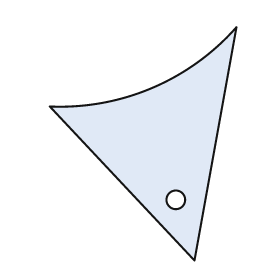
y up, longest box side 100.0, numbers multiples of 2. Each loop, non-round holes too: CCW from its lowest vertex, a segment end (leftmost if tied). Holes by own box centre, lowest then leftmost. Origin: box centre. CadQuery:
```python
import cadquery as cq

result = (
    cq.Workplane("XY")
    .moveTo(22.0, -50.0)
    .lineTo(40.0, 50.0)
    .threePointArc((4.0, 24.0), (-40.0, 16.0))
    .close()
    .moveTo(14.0, -24.0)
    .circle(4.0)
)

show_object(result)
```